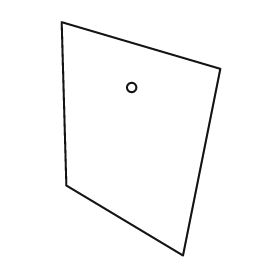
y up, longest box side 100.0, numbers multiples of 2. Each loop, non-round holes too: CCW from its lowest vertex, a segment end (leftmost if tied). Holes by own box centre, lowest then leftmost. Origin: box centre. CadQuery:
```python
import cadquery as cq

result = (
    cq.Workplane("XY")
    .moveTo(18.0, -50.0)
    .lineTo(34.0, 30.0)
    .lineTo(-34.0, 50.0)
    .lineTo(-32.0, -20.0)
    .close()
    .moveTo(-4.0, 22.0)
    .circle(2.0)
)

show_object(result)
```